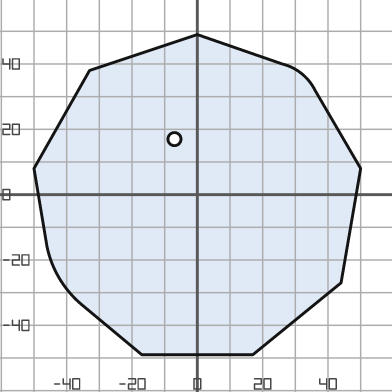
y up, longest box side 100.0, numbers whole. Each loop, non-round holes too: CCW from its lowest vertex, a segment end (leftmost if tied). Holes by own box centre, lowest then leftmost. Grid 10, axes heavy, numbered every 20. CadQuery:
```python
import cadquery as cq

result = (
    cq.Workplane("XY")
    .moveTo(-17.0, -49.0)
    .lineTo(17.0, -49.0)
    .lineTo(44.0, -27.0)
    .lineTo(50.0, 8.0)
    .lineTo(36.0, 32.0)
    .threePointArc((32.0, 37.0), (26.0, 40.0))
    .lineTo(0.0, 49.0)
    .lineTo(-33.0, 38.0)
    .lineTo(-50.0, 8.0)
    .lineTo(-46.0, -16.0)
    .threePointArc((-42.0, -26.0), (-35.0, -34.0))
    .close()
    .moveTo(-7.0, 17.0)
    .circle(2.0)
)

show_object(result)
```